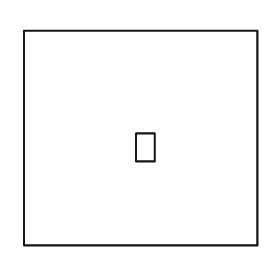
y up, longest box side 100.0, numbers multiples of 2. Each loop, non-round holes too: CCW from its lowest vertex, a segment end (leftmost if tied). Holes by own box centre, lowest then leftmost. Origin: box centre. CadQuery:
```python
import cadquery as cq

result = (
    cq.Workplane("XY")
    .moveTo(-50.0, -46.0)
    .lineTo(50.0, -46.0)
    .lineTo(50.0, 46.0)
    .lineTo(-50.0, 46.0)
    .close()
    .moveTo(-2.0, -10.0)
    .lineTo(6.0, -10.0)
    .lineTo(6.0, 2.0)
    .lineTo(-2.0, 2.0)
    .close()
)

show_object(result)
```